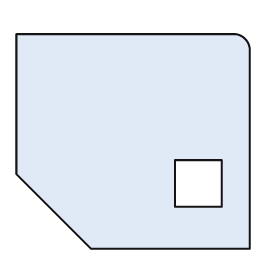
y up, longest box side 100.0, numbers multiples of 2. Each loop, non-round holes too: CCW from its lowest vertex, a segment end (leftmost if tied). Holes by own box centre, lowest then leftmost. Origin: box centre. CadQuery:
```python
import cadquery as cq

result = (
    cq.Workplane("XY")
    .moveTo(-18.0, -46.0)
    .lineTo(50.0, -46.0)
    .lineTo(50.0, 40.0)
    .threePointArc((48.0, 44.0), (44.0, 46.0))
    .lineTo(-50.0, 46.0)
    .lineTo(-50.0, -14.0)
    .close()
    .moveTo(18.0, -28.0)
    .lineTo(38.0, -28.0)
    .lineTo(38.0, -8.0)
    .lineTo(18.0, -8.0)
    .close()
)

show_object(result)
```